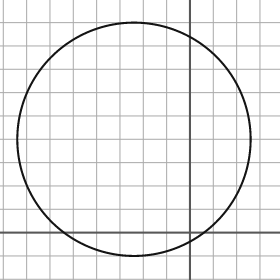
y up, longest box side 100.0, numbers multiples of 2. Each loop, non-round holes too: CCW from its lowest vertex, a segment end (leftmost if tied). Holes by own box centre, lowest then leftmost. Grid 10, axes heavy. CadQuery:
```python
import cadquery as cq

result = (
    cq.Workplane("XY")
    .moveTo(-24.0, 40.0)
    .circle(50.0)
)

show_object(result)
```